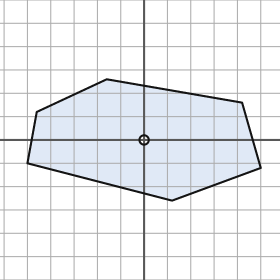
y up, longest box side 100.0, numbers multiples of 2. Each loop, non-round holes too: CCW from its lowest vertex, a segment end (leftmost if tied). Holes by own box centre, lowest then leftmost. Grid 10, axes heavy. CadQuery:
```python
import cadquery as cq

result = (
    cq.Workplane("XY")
    .moveTo(12.0, -26.0)
    .lineTo(50.0, -12.0)
    .lineTo(42.0, 16.0)
    .lineTo(-16.0, 26.0)
    .lineTo(-46.0, 12.0)
    .lineTo(-50.0, -10.0)
    .close()
    .moveTo(0.0, 0.0)
    .circle(2.0)
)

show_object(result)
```